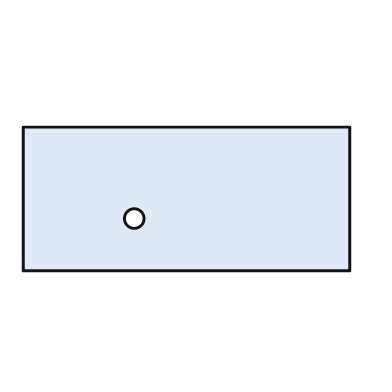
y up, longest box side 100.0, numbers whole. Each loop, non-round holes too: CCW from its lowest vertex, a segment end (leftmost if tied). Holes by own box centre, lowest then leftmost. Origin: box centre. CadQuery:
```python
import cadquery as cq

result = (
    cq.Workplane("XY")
    .moveTo(-50.0, -22.0)
    .lineTo(50.0, -22.0)
    .lineTo(50.0, 22.0)
    .lineTo(-50.0, 22.0)
    .close()
    .moveTo(-16.0, -6.0)
    .circle(3.0)
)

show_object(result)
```